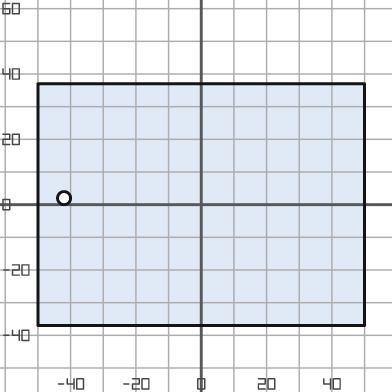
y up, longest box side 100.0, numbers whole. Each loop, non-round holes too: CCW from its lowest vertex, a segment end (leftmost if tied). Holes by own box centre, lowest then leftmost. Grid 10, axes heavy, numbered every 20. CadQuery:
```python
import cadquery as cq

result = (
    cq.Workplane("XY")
    .moveTo(-50.0, -37.0)
    .lineTo(50.0, -37.0)
    .lineTo(50.0, 37.0)
    .lineTo(-50.0, 37.0)
    .close()
    .moveTo(-42.0, 2.0)
    .circle(2.0)
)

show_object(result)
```